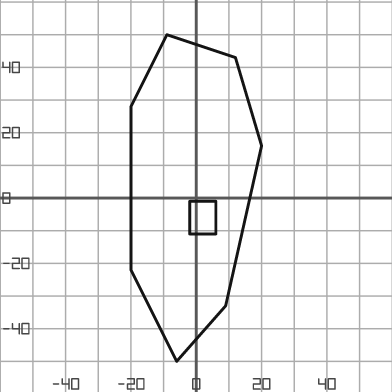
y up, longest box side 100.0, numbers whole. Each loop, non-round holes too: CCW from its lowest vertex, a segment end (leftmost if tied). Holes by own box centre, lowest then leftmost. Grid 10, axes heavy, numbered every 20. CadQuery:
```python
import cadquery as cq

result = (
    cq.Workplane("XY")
    .moveTo(-6.0, -50.0)
    .lineTo(9.0, -33.0)
    .lineTo(20.0, 16.0)
    .lineTo(12.0, 43.0)
    .lineTo(-9.0, 50.0)
    .lineTo(-20.0, 28.0)
    .lineTo(-20.0, -22.0)
    .close()
    .moveTo(-2.0, -11.0)
    .lineTo(6.0, -11.0)
    .lineTo(6.0, -1.0)
    .lineTo(-2.0, -1.0)
    .close()
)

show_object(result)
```